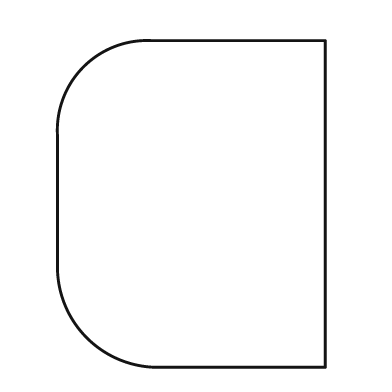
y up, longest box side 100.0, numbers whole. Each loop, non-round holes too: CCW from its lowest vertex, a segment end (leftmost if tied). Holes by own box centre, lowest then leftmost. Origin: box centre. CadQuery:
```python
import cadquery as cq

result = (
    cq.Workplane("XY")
    .moveTo(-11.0, -50.0)
    .lineTo(41.0, -50.0)
    .lineTo(41.0, 50.0)
    .lineTo(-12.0, 50.0)
    .threePointArc((-33.0, 42.0), (-41.0, 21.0))
    .lineTo(-41.0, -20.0)
    .threePointArc((-32.0, -41.0), (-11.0, -50.0))
    .close()
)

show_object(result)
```